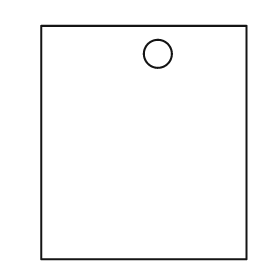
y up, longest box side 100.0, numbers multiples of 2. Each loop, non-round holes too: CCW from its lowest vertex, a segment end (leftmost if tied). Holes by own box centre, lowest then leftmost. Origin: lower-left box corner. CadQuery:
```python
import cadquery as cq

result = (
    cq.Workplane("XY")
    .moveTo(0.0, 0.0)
    .lineTo(88.0, 0.0)
    .lineTo(88.0, 100.0)
    .lineTo(0.0, 100.0)
    .close()
    .moveTo(50.0, 88.0)
    .circle(6.0)
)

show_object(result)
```